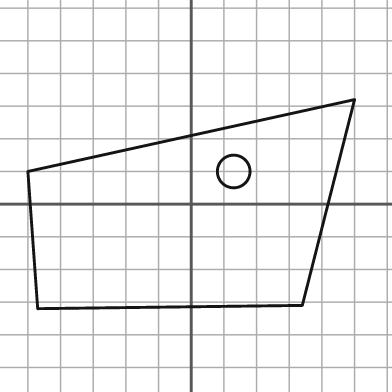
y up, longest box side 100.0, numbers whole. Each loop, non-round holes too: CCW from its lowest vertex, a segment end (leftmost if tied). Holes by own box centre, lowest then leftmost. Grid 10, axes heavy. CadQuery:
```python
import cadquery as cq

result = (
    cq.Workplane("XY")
    .moveTo(-47.0, -32.0)
    .lineTo(34.0, -31.0)
    .lineTo(50.0, 32.0)
    .lineTo(-50.0, 10.0)
    .close()
    .moveTo(13.0, 10.0)
    .circle(5.0)
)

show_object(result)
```